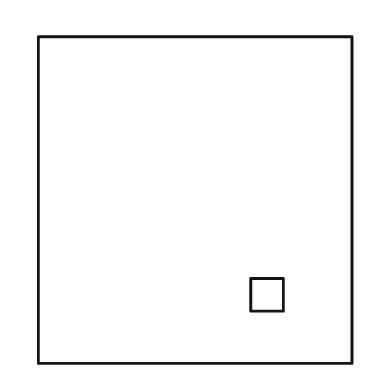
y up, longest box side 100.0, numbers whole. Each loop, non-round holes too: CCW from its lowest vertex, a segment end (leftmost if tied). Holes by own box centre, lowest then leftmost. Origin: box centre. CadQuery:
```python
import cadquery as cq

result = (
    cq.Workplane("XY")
    .moveTo(-48.0, -50.0)
    .lineTo(48.0, -50.0)
    .lineTo(48.0, 50.0)
    .lineTo(-48.0, 50.0)
    .close()
    .moveTo(17.0, -34.0)
    .lineTo(27.0, -34.0)
    .lineTo(27.0, -24.0)
    .lineTo(17.0, -24.0)
    .close()
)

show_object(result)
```